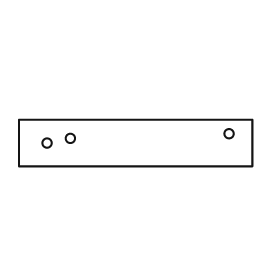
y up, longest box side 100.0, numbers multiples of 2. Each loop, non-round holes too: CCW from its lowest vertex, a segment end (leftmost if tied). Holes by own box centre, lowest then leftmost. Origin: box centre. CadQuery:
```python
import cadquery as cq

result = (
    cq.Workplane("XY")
    .moveTo(-50.0, -10.0)
    .lineTo(50.0, -10.0)
    .lineTo(50.0, 10.0)
    .lineTo(-50.0, 10.0)
    .close()
    .moveTo(-38.0, 0.0)
    .circle(2.0)
    .moveTo(-28.0, 2.0)
    .circle(2.0)
    .moveTo(40.0, 4.0)
    .circle(2.0)
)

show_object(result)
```